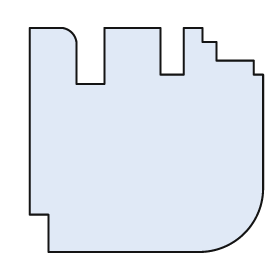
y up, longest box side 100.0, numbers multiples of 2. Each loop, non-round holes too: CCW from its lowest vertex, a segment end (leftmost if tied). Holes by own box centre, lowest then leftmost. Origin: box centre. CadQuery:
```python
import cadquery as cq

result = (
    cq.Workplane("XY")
    .moveTo(-42.0, -48.0)
    .lineTo(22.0, -48.0)
    .threePointArc((42.0, -40.0), (50.0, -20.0))
    .lineTo(50.0, 28.0)
    .lineTo(46.0, 28.0)
    .lineTo(46.0, 34.0)
    .lineTo(30.0, 34.0)
    .lineTo(30.0, 42.0)
    .lineTo(24.0, 42.0)
    .lineTo(24.0, 48.0)
    .lineTo(16.0, 48.0)
    .lineTo(16.0, 28.0)
    .lineTo(6.0, 28.0)
    .lineTo(6.0, 48.0)
    .lineTo(-18.0, 48.0)
    .lineTo(-18.0, 24.0)
    .lineTo(-30.0, 24.0)
    .lineTo(-30.0, 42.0)
    .threePointArc((-32.0, 46.0), (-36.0, 48.0))
    .lineTo(-50.0, 48.0)
    .lineTo(-50.0, -32.0)
    .lineTo(-42.0, -32.0)
    .close()
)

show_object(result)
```